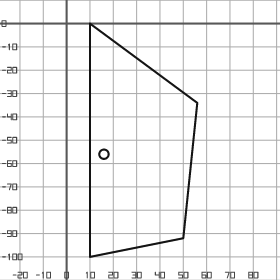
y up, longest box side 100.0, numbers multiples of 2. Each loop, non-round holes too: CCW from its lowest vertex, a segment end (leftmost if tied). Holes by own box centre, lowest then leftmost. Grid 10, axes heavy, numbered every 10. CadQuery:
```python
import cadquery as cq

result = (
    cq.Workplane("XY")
    .moveTo(10.0, -100.0)
    .lineTo(50.0, -92.0)
    .lineTo(56.0, -34.0)
    .lineTo(10.0, 0.0)
    .close()
    .moveTo(16.0, -56.0)
    .circle(2.0)
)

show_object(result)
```